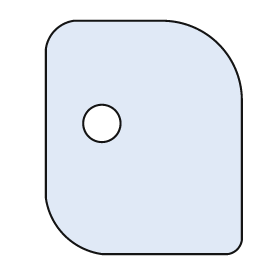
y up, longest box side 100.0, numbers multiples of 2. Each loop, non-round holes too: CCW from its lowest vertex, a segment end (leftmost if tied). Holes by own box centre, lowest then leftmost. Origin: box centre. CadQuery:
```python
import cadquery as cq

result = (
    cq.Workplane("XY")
    .moveTo(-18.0, -50.0)
    .lineTo(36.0, -50.0)
    .threePointArc((40.0, -48.0), (42.0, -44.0))
    .lineTo(42.0, 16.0)
    .threePointArc((32.0, 40.0), (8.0, 50.0))
    .lineTo(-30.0, 50.0)
    .threePointArc((-38.0, 46.0), (-42.0, 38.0))
    .lineTo(-42.0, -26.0)
    .threePointArc((-34.0, -42.0), (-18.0, -50.0))
    .close()
    .moveTo(-18.0, 6.0)
    .circle(8.0)
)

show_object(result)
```